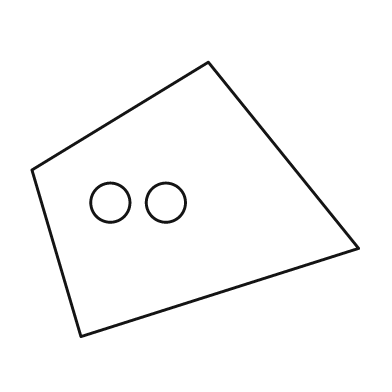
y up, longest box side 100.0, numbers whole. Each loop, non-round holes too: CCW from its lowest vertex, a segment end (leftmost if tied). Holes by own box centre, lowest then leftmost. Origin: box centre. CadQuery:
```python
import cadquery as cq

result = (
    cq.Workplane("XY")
    .moveTo(-35.0, -42.0)
    .lineTo(50.0, -15.0)
    .lineTo(4.0, 42.0)
    .lineTo(-50.0, 9.0)
    .close()
    .moveTo(-26.0, -1.0)
    .circle(6.0)
    .moveTo(-9.0, -1.0)
    .circle(6.0)
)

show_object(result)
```